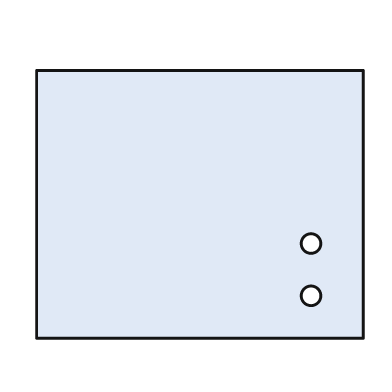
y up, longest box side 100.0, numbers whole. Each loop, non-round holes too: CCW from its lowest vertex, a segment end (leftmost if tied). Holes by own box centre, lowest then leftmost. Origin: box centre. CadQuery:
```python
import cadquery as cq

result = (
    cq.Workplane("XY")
    .moveTo(-50.0, -41.0)
    .lineTo(50.0, -41.0)
    .lineTo(50.0, 41.0)
    .lineTo(-50.0, 41.0)
    .close()
    .moveTo(34.0, -28.0)
    .circle(3.0)
    .moveTo(34.0, -12.0)
    .circle(3.0)
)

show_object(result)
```